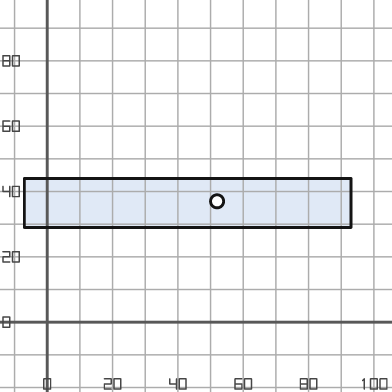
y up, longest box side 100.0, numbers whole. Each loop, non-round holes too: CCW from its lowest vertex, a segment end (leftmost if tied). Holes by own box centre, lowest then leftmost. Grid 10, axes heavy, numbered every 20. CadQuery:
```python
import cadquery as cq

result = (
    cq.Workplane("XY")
    .moveTo(-7.0, 29.0)
    .lineTo(93.0, 29.0)
    .lineTo(93.0, 44.0)
    .lineTo(-7.0, 44.0)
    .close()
    .moveTo(52.0, 37.0)
    .circle(2.0)
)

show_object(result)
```